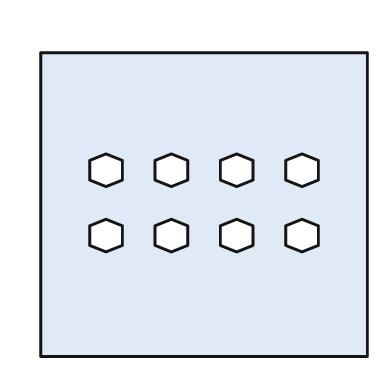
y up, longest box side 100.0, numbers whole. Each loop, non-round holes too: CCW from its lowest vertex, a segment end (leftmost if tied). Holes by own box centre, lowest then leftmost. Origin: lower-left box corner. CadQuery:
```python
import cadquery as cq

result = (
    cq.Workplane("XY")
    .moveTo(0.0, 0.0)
    .lineTo(100.0, 0.0)
    .lineTo(100.0, 93.0)
    .lineTo(0.0, 93.0)
    .close()
    .moveTo(20.0, 32.0)
    .lineTo(25.0, 34.0)
    .lineTo(25.0, 40.0)
    .lineTo(20.0, 42.0)
    .lineTo(15.0, 40.0)
    .lineTo(15.0, 34.0)
    .close()
    .moveTo(40.0, 32.0)
    .lineTo(45.0, 34.0)
    .lineTo(45.0, 40.0)
    .lineTo(40.0, 42.0)
    .lineTo(35.0, 40.0)
    .lineTo(35.0, 34.0)
    .close()
    .moveTo(60.0, 32.0)
    .lineTo(65.0, 34.0)
    .lineTo(65.0, 40.0)
    .lineTo(60.0, 42.0)
    .lineTo(55.0, 40.0)
    .lineTo(55.0, 34.0)
    .close()
    .moveTo(80.0, 32.0)
    .lineTo(85.0, 34.0)
    .lineTo(85.0, 40.0)
    .lineTo(80.0, 42.0)
    .lineTo(75.0, 40.0)
    .lineTo(75.0, 34.0)
    .close()
    .moveTo(20.0, 52.0)
    .lineTo(25.0, 54.0)
    .lineTo(25.0, 60.0)
    .lineTo(20.0, 62.0)
    .lineTo(15.0, 60.0)
    .lineTo(15.0, 54.0)
    .close()
    .moveTo(40.0, 52.0)
    .lineTo(45.0, 54.0)
    .lineTo(45.0, 60.0)
    .lineTo(40.0, 62.0)
    .lineTo(35.0, 60.0)
    .lineTo(35.0, 54.0)
    .close()
    .moveTo(60.0, 52.0)
    .lineTo(65.0, 54.0)
    .lineTo(65.0, 60.0)
    .lineTo(60.0, 62.0)
    .lineTo(55.0, 60.0)
    .lineTo(55.0, 54.0)
    .close()
    .moveTo(80.0, 52.0)
    .lineTo(85.0, 54.0)
    .lineTo(85.0, 60.0)
    .lineTo(80.0, 62.0)
    .lineTo(75.0, 60.0)
    .lineTo(75.0, 54.0)
    .close()
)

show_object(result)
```